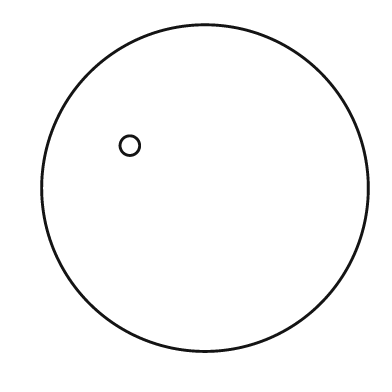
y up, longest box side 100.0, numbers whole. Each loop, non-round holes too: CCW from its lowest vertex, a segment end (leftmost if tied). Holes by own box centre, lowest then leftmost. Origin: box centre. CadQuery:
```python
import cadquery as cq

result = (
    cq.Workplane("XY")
    .moveTo(0.0, 0.0)
    .circle(50.0)
    .moveTo(-23.0, 13.0)
    .circle(3.0)
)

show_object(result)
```